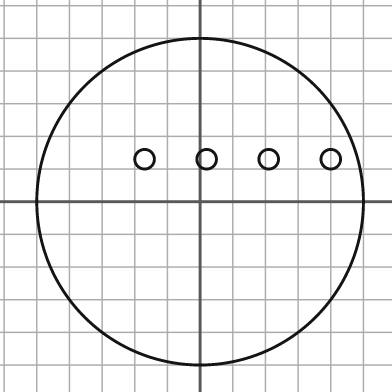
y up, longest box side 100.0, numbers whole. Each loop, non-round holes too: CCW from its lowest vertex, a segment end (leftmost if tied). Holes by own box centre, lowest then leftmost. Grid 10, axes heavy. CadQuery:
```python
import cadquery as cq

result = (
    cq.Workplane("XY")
    .moveTo(0.0, 0.0)
    .circle(50.0)
    .moveTo(-17.0, 13.0)
    .circle(3.0)
    .moveTo(2.0, 13.0)
    .circle(3.0)
    .moveTo(21.0, 13.0)
    .circle(3.0)
    .moveTo(40.0, 13.0)
    .circle(3.0)
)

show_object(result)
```